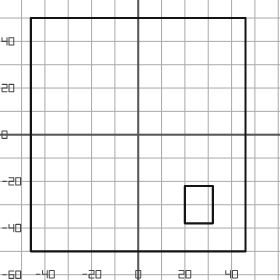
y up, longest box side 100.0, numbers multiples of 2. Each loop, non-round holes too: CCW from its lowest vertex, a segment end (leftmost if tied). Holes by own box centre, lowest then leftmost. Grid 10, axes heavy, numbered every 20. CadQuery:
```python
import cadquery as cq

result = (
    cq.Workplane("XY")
    .moveTo(-46.0, -50.0)
    .lineTo(46.0, -50.0)
    .lineTo(46.0, 50.0)
    .lineTo(-46.0, 50.0)
    .close()
    .moveTo(20.0, -38.0)
    .lineTo(32.0, -38.0)
    .lineTo(32.0, -22.0)
    .lineTo(20.0, -22.0)
    .close()
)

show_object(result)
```